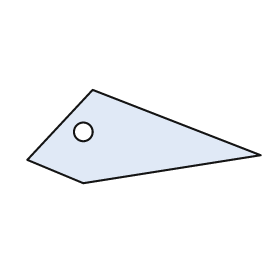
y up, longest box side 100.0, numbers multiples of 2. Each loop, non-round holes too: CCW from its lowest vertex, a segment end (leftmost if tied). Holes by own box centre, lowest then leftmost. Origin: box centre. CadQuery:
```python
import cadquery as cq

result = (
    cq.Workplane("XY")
    .moveTo(-26.0, -20.0)
    .lineTo(50.0, -8.0)
    .lineTo(-22.0, 20.0)
    .lineTo(-50.0, -10.0)
    .close()
    .moveTo(-26.0, 2.0)
    .circle(4.0)
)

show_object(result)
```